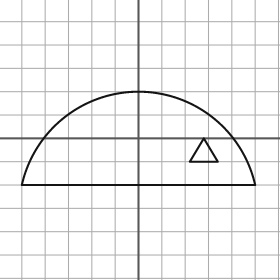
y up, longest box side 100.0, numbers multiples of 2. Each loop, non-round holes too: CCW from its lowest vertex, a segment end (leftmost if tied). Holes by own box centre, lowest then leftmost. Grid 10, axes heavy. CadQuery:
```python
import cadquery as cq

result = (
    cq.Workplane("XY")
    .moveTo(-50.0, -20.0)
    .lineTo(50.0, -20.0)
    .threePointArc((0.0, 20.0), (-50.0, -20.0))
    .close()
    .moveTo(22.0, -10.0)
    .lineTo(34.0, -10.0)
    .lineTo(28.0, 0.0)
    .close()
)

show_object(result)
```